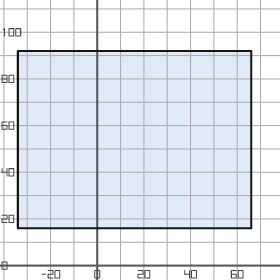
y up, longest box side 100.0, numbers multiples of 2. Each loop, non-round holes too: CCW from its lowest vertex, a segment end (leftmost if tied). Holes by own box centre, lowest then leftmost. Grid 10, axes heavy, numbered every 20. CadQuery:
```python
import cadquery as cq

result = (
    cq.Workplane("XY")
    .moveTo(-34.0, 16.0)
    .lineTo(66.0, 16.0)
    .lineTo(66.0, 92.0)
    .lineTo(-34.0, 92.0)
    .close()
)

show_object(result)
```